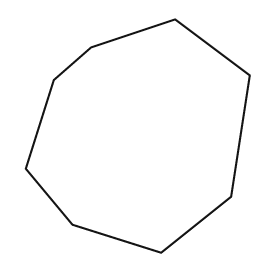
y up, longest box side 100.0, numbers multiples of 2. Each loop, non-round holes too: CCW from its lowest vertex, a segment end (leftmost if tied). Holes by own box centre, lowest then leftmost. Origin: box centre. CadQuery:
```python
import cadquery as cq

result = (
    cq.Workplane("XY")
    .moveTo(10.0, -50.0)
    .lineTo(40.0, -26.0)
    .lineTo(48.0, 26.0)
    .lineTo(16.0, 50.0)
    .lineTo(-20.0, 38.0)
    .lineTo(-36.0, 24.0)
    .lineTo(-48.0, -14.0)
    .lineTo(-28.0, -38.0)
    .close()
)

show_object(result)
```